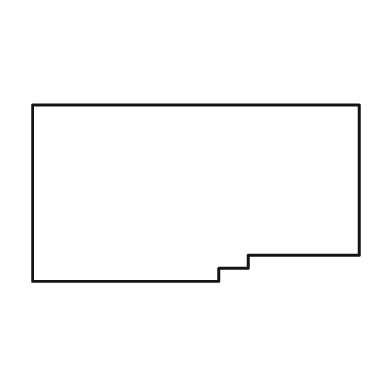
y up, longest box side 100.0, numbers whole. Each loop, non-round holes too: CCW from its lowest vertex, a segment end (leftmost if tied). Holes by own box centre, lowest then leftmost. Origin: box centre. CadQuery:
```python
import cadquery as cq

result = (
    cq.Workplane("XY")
    .moveTo(-50.0, -27.0)
    .lineTo(7.0, -27.0)
    .lineTo(7.0, -23.0)
    .lineTo(16.0, -23.0)
    .lineTo(16.0, -19.0)
    .lineTo(50.0, -19.0)
    .lineTo(50.0, 27.0)
    .lineTo(-50.0, 27.0)
    .close()
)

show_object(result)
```